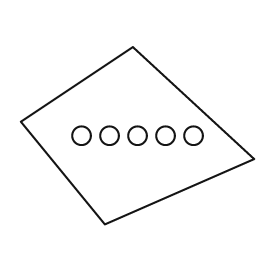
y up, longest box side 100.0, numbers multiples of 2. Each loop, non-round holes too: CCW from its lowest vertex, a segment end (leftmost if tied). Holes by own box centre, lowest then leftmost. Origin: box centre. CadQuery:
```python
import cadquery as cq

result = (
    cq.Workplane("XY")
    .moveTo(-14.0, -38.0)
    .lineTo(50.0, -10.0)
    .lineTo(-2.0, 38.0)
    .lineTo(-50.0, 6.0)
    .close()
    .moveTo(-24.0, 0.0)
    .circle(4.0)
    .moveTo(-12.0, 0.0)
    .circle(4.0)
    .moveTo(0.0, 0.0)
    .circle(4.0)
    .moveTo(12.0, 0.0)
    .circle(4.0)
    .moveTo(24.0, 0.0)
    .circle(4.0)
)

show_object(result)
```